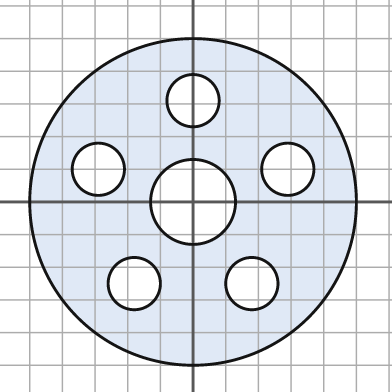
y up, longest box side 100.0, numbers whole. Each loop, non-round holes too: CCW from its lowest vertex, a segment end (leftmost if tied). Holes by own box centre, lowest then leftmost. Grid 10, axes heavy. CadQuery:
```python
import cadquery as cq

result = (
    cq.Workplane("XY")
    .moveTo(0.0, 0.0)
    .circle(50.0)
    .moveTo(-18.0, -25.0)
    .circle(8.0)
    .moveTo(18.0, -25.0)
    .circle(8.0)
    .moveTo(0.0, 0.0)
    .circle(13.0)
    .moveTo(-29.0, 10.0)
    .circle(8.0)
    .moveTo(29.0, 10.0)
    .circle(8.0)
    .moveTo(0.0, 31.0)
    .circle(8.0)
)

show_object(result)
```